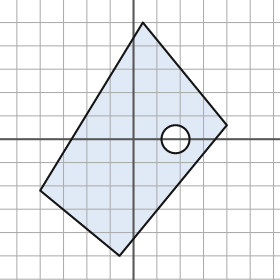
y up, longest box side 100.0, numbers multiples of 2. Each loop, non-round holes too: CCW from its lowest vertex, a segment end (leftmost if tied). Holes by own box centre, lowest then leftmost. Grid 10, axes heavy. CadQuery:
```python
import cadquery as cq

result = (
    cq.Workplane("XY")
    .moveTo(-6.0, -50.0)
    .lineTo(40.0, 6.0)
    .lineTo(4.0, 50.0)
    .lineTo(-40.0, -22.0)
    .close()
    .moveTo(18.0, 0.0)
    .circle(6.0)
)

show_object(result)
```